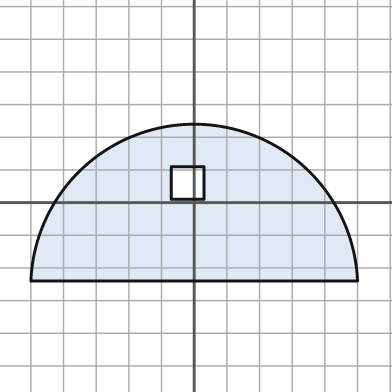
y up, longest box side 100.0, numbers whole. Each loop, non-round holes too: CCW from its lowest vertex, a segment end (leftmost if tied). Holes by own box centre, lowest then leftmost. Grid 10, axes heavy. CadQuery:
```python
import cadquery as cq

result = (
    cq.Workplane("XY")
    .moveTo(-50.0, -24.0)
    .lineTo(50.0, -24.0)
    .threePointArc((0.0, 24.0), (-50.0, -24.0))
    .close()
    .moveTo(-7.0, 1.0)
    .lineTo(3.0, 1.0)
    .lineTo(3.0, 11.0)
    .lineTo(-7.0, 11.0)
    .close()
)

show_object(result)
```